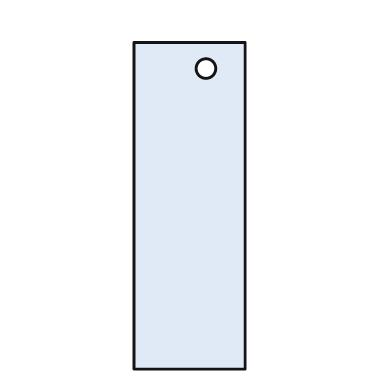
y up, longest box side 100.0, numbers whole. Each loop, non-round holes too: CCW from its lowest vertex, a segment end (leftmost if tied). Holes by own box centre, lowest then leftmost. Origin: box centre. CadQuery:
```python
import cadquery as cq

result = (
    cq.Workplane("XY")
    .moveTo(-17.0, -50.0)
    .lineTo(17.0, -50.0)
    .lineTo(17.0, 50.0)
    .lineTo(-17.0, 50.0)
    .close()
    .moveTo(5.0, 42.0)
    .circle(3.0)
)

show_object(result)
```